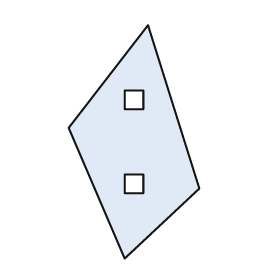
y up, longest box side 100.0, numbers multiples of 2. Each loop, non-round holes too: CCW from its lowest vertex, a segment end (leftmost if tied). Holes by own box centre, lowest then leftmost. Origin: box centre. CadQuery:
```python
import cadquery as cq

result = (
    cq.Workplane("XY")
    .moveTo(-4.0, -50.0)
    .lineTo(28.0, -20.0)
    .lineTo(6.0, 50.0)
    .lineTo(-28.0, 6.0)
    .close()
    .moveTo(-4.0, -22.0)
    .lineTo(4.0, -22.0)
    .lineTo(4.0, -14.0)
    .lineTo(-4.0, -14.0)
    .close()
    .moveTo(-4.0, 14.0)
    .lineTo(4.0, 14.0)
    .lineTo(4.0, 22.0)
    .lineTo(-4.0, 22.0)
    .close()
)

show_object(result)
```